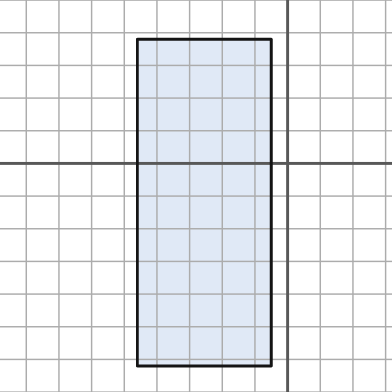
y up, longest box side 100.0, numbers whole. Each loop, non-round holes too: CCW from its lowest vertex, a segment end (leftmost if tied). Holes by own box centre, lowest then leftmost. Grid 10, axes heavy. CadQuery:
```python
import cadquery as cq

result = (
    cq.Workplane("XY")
    .moveTo(-46.0, -62.0)
    .lineTo(-5.0, -62.0)
    .lineTo(-5.0, 38.0)
    .lineTo(-46.0, 38.0)
    .close()
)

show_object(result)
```